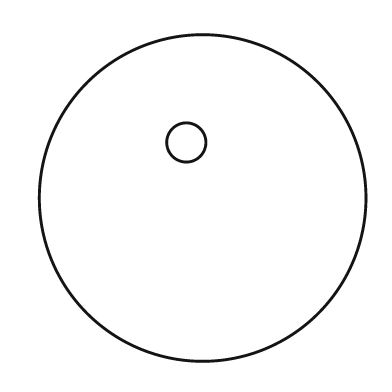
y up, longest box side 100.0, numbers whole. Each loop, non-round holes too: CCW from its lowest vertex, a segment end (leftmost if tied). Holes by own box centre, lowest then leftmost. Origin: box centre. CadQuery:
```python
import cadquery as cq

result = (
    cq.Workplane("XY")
    .moveTo(0.0, 0.0)
    .circle(50.0)
    .moveTo(-5.0, 17.0)
    .circle(6.0)
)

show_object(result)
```